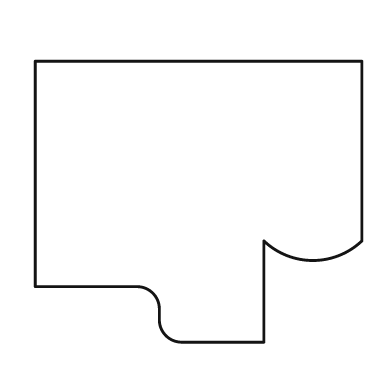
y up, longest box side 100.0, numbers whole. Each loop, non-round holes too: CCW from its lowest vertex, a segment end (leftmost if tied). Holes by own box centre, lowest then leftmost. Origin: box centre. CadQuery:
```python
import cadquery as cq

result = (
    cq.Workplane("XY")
    .moveTo(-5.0, -43.0)
    .lineTo(20.0, -43.0)
    .lineTo(20.0, -12.0)
    .threePointArc((35.0, -18.0), (50.0, -12.0))
    .lineTo(50.0, 43.0)
    .lineTo(-50.0, 43.0)
    .lineTo(-50.0, -26.0)
    .lineTo(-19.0, -26.0)
    .threePointArc((-14.0, -28.0), (-12.0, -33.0))
    .lineTo(-12.0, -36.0)
    .threePointArc((-10.0, -41.0), (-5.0, -43.0))
    .close()
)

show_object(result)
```